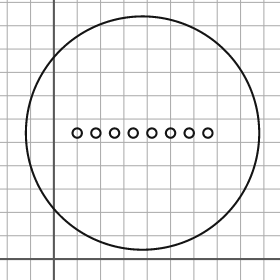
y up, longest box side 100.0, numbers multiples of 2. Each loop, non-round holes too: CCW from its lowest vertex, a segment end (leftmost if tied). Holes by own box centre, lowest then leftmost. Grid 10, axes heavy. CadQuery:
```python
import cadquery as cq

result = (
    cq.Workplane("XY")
    .moveTo(38.0, 54.0)
    .circle(50.0)
    .moveTo(10.0, 54.0)
    .circle(2.0)
    .moveTo(18.0, 54.0)
    .circle(2.0)
    .moveTo(26.0, 54.0)
    .circle(2.0)
    .moveTo(34.0, 54.0)
    .circle(2.0)
    .moveTo(42.0, 54.0)
    .circle(2.0)
    .moveTo(50.0, 54.0)
    .circle(2.0)
    .moveTo(58.0, 54.0)
    .circle(2.0)
    .moveTo(66.0, 54.0)
    .circle(2.0)
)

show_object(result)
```